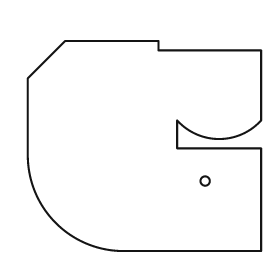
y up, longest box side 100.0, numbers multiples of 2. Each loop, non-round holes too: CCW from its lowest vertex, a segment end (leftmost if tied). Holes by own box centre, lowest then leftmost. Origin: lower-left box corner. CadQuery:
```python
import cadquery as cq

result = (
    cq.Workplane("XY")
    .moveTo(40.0, 0.0)
    .lineTo(100.0, 0.0)
    .lineTo(100.0, 44.0)
    .lineTo(64.0, 44.0)
    .lineTo(64.0, 56.0)
    .threePointArc((82.0, 48.0), (100.0, 56.0))
    .lineTo(100.0, 86.0)
    .lineTo(56.0, 86.0)
    .lineTo(56.0, 90.0)
    .lineTo(16.0, 90.0)
    .lineTo(0.0, 74.0)
    .lineTo(0.0, 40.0)
    .threePointArc((12.0, 12.0), (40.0, 0.0))
    .close()
    .moveTo(76.0, 30.0)
    .circle(2.0)
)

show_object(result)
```